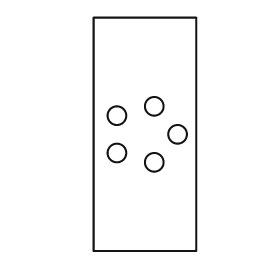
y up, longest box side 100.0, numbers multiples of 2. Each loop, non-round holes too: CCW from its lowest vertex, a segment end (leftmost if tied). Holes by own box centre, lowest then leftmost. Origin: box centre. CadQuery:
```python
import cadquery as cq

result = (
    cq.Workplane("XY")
    .moveTo(-22.0, -50.0)
    .lineTo(22.0, -50.0)
    .lineTo(22.0, 50.0)
    .lineTo(-22.0, 50.0)
    .close()
    .moveTo(4.0, -12.0)
    .circle(4.0)
    .moveTo(-12.0, -8.0)
    .circle(4.0)
    .moveTo(14.0, 0.0)
    .circle(4.0)
    .moveTo(-12.0, 8.0)
    .circle(4.0)
    .moveTo(4.0, 12.0)
    .circle(4.0)
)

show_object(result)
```